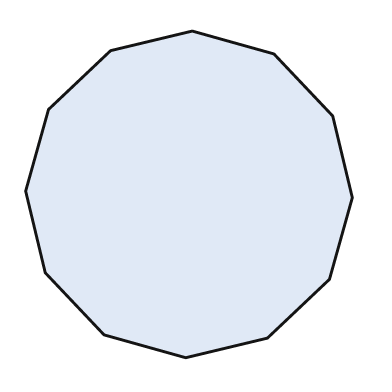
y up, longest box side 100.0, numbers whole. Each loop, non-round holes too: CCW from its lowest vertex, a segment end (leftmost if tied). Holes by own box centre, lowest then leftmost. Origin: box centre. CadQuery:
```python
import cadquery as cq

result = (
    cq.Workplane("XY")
    .moveTo(-1.0, -50.0)
    .lineTo(24.0, -44.0)
    .lineTo(43.0, -26.0)
    .lineTo(50.0, -1.0)
    .lineTo(44.0, 24.0)
    .lineTo(26.0, 43.0)
    .lineTo(1.0, 50.0)
    .lineTo(-24.0, 44.0)
    .lineTo(-43.0, 26.0)
    .lineTo(-50.0, 1.0)
    .lineTo(-44.0, -24.0)
    .lineTo(-26.0, -43.0)
    .close()
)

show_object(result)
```